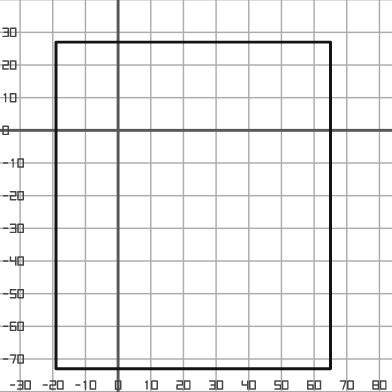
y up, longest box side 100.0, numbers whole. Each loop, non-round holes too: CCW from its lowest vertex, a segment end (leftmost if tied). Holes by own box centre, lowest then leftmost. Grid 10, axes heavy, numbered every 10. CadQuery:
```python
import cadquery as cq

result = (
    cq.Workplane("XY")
    .moveTo(-19.0, -73.0)
    .lineTo(65.0, -73.0)
    .lineTo(65.0, 27.0)
    .lineTo(-19.0, 27.0)
    .close()
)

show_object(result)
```